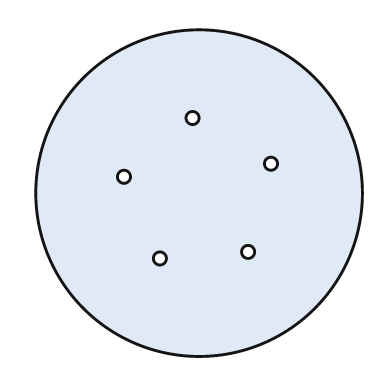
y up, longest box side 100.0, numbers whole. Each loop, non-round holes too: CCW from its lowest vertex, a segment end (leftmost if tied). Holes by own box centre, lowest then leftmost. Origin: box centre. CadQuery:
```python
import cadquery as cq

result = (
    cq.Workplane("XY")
    .moveTo(0.0, 0.0)
    .circle(50.0)
    .moveTo(-12.0, -20.0)
    .circle(2.0)
    .moveTo(15.0, -18.0)
    .circle(2.0)
    .moveTo(-23.0, 5.0)
    .circle(2.0)
    .moveTo(22.0, 9.0)
    .circle(2.0)
    .moveTo(-2.0, 23.0)
    .circle(2.0)
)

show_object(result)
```